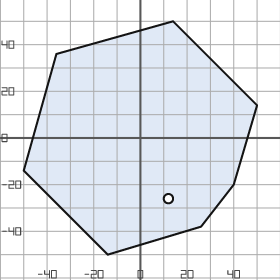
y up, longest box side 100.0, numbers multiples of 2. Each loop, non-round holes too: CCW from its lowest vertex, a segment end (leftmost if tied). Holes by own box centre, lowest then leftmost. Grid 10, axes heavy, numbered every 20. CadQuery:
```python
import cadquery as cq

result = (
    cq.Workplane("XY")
    .moveTo(-14.0, -50.0)
    .lineTo(26.0, -38.0)
    .lineTo(40.0, -20.0)
    .lineTo(50.0, 14.0)
    .lineTo(14.0, 50.0)
    .lineTo(-36.0, 36.0)
    .lineTo(-50.0, -14.0)
    .close()
    .moveTo(12.0, -26.0)
    .circle(2.0)
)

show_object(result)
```